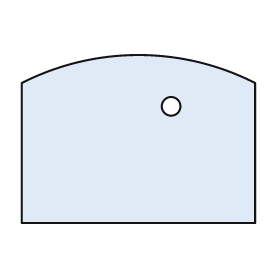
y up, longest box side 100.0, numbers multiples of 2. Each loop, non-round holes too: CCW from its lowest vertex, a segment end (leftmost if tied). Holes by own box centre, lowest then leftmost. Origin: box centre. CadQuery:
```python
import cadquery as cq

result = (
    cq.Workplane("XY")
    .moveTo(-50.0, -36.0)
    .lineTo(50.0, -36.0)
    .lineTo(50.0, 24.0)
    .threePointArc((0.0, 36.0), (-50.0, 24.0))
    .close()
    .moveTo(14.0, 14.0)
    .circle(4.0)
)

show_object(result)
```